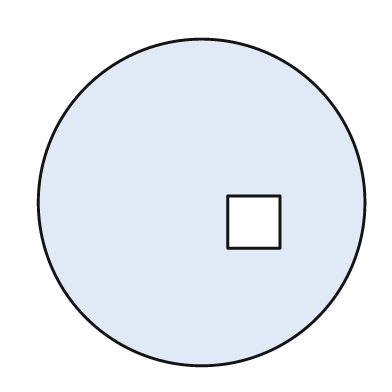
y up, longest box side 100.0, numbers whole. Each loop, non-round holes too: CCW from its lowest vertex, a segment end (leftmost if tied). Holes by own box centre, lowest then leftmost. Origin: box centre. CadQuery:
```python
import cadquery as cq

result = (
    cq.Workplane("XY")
    .moveTo(0.0, 0.0)
    .circle(50.0)
    .moveTo(8.0, -14.0)
    .lineTo(24.0, -14.0)
    .lineTo(24.0, 2.0)
    .lineTo(8.0, 2.0)
    .close()
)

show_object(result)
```